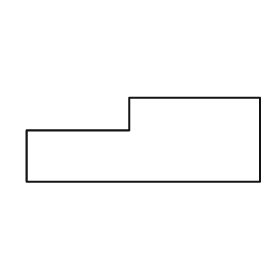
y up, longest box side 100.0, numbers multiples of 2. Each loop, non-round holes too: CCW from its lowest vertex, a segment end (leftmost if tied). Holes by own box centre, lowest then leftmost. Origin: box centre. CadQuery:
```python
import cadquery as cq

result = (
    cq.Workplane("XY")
    .moveTo(-50.0, -18.0)
    .lineTo(50.0, -18.0)
    .lineTo(50.0, 18.0)
    .lineTo(-6.0, 18.0)
    .lineTo(-6.0, 4.0)
    .lineTo(-50.0, 4.0)
    .close()
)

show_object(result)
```